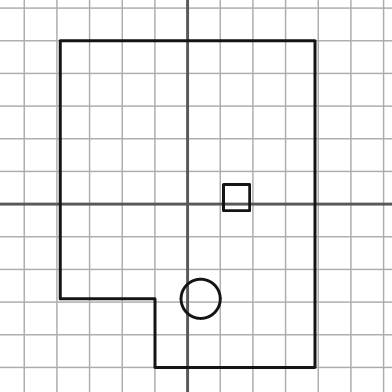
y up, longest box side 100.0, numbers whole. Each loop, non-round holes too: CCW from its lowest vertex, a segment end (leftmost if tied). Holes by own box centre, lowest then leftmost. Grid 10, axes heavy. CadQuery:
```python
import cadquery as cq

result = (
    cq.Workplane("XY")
    .moveTo(-10.0, -50.0)
    .lineTo(39.0, -50.0)
    .lineTo(39.0, 50.0)
    .lineTo(-39.0, 50.0)
    .lineTo(-39.0, -29.0)
    .lineTo(-10.0, -29.0)
    .close()
    .moveTo(4.0, -29.0)
    .circle(6.0)
    .moveTo(11.0, -2.0)
    .lineTo(19.0, -2.0)
    .lineTo(19.0, 6.0)
    .lineTo(11.0, 6.0)
    .close()
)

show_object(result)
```